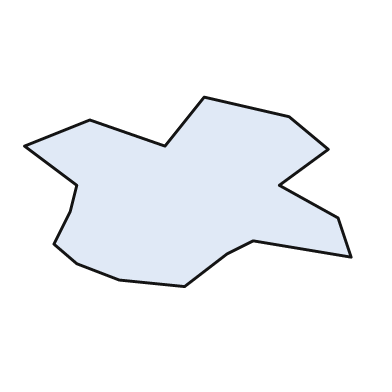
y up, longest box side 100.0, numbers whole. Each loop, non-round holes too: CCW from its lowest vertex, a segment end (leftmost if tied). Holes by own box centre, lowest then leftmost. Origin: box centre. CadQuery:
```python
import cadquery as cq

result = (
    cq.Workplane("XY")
    .moveTo(-1.0, -29.0)
    .lineTo(12.0, -19.0)
    .lineTo(20.0, -15.0)
    .lineTo(50.0, -20.0)
    .lineTo(46.0, -8.0)
    .lineTo(28.0, 2.0)
    .lineTo(43.0, 13.0)
    .lineTo(31.0, 23.0)
    .lineTo(5.0, 29.0)
    .lineTo(-7.0, 14.0)
    .lineTo(-30.0, 22.0)
    .lineTo(-50.0, 14.0)
    .lineTo(-34.0, 2.0)
    .lineTo(-36.0, -6.0)
    .lineTo(-41.0, -16.0)
    .lineTo(-34.0, -22.0)
    .lineTo(-21.0, -27.0)
    .close()
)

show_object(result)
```